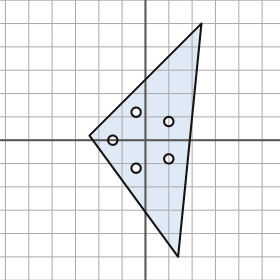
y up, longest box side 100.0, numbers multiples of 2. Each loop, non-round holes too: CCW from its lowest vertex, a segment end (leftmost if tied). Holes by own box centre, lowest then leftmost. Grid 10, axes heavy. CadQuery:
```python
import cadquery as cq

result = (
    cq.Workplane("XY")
    .moveTo(14.0, -50.0)
    .lineTo(24.0, 50.0)
    .lineTo(-24.0, 2.0)
    .close()
    .moveTo(-4.0, -12.0)
    .circle(2.0)
    .moveTo(10.0, -8.0)
    .circle(2.0)
    .moveTo(-14.0, 0.0)
    .circle(2.0)
    .moveTo(10.0, 8.0)
    .circle(2.0)
    .moveTo(-4.0, 12.0)
    .circle(2.0)
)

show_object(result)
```